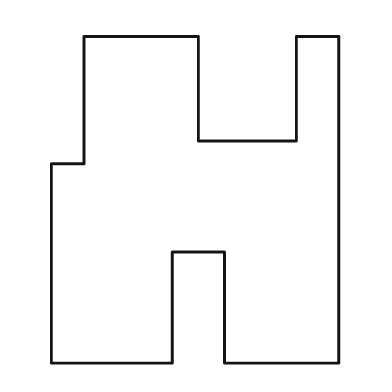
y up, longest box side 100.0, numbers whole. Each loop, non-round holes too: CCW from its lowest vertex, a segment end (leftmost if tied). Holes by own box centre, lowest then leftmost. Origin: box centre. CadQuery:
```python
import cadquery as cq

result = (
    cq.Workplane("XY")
    .moveTo(-44.0, -50.0)
    .lineTo(-7.0, -50.0)
    .lineTo(-7.0, -16.0)
    .lineTo(9.0, -16.0)
    .lineTo(9.0, -50.0)
    .lineTo(44.0, -50.0)
    .lineTo(44.0, 50.0)
    .lineTo(31.0, 50.0)
    .lineTo(31.0, 18.0)
    .lineTo(1.0, 18.0)
    .lineTo(1.0, 50.0)
    .lineTo(-34.0, 50.0)
    .lineTo(-34.0, 11.0)
    .lineTo(-44.0, 11.0)
    .close()
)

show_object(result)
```